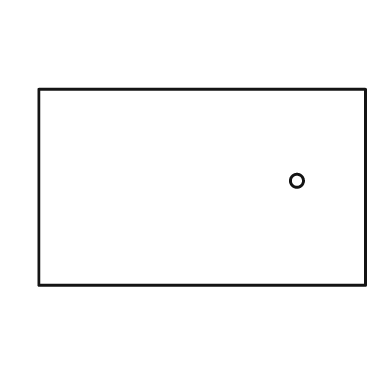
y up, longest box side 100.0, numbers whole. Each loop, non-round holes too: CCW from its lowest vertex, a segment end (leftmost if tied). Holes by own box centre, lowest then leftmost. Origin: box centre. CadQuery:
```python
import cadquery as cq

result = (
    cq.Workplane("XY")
    .moveTo(-50.0, -30.0)
    .lineTo(50.0, -30.0)
    .lineTo(50.0, 30.0)
    .lineTo(-50.0, 30.0)
    .close()
    .moveTo(29.0, 2.0)
    .circle(2.0)
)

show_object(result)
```